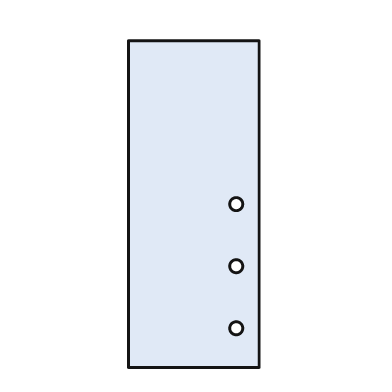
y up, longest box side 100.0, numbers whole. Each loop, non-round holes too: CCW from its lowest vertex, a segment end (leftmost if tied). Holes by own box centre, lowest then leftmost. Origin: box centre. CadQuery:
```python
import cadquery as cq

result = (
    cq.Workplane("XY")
    .moveTo(-20.0, -50.0)
    .lineTo(20.0, -50.0)
    .lineTo(20.0, 50.0)
    .lineTo(-20.0, 50.0)
    .close()
    .moveTo(13.0, -38.0)
    .circle(2.0)
    .moveTo(13.0, -19.0)
    .circle(2.0)
    .moveTo(13.0, 0.0)
    .circle(2.0)
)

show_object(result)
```